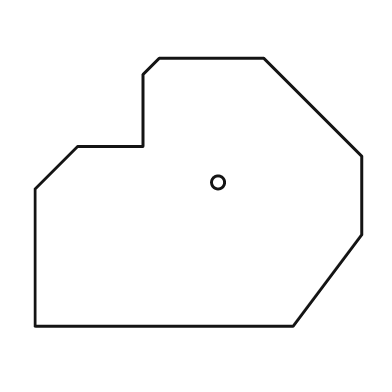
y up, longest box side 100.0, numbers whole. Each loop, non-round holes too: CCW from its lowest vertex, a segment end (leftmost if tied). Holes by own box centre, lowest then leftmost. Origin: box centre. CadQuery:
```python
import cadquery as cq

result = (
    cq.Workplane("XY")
    .moveTo(-50.0, -41.0)
    .lineTo(29.0, -41.0)
    .lineTo(50.0, -13.0)
    .lineTo(50.0, 11.0)
    .lineTo(20.0, 41.0)
    .lineTo(-12.0, 41.0)
    .lineTo(-17.0, 36.0)
    .lineTo(-17.0, 14.0)
    .lineTo(-37.0, 14.0)
    .lineTo(-50.0, 1.0)
    .close()
    .moveTo(6.0, 3.0)
    .circle(2.0)
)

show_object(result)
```